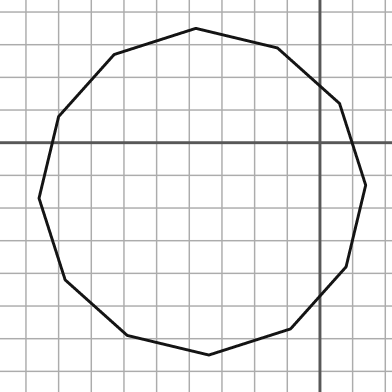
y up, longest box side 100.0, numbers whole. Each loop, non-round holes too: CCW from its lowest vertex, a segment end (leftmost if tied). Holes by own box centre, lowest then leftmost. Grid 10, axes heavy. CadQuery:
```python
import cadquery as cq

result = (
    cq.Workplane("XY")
    .moveTo(-34.0, -65.0)
    .lineTo(-9.0, -57.0)
    .lineTo(8.0, -38.0)
    .lineTo(14.0, -13.0)
    .lineTo(6.0, 12.0)
    .lineTo(-13.0, 29.0)
    .lineTo(-38.0, 35.0)
    .lineTo(-63.0, 27.0)
    .lineTo(-80.0, 8.0)
    .lineTo(-86.0, -17.0)
    .lineTo(-78.0, -42.0)
    .lineTo(-59.0, -59.0)
    .close()
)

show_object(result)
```